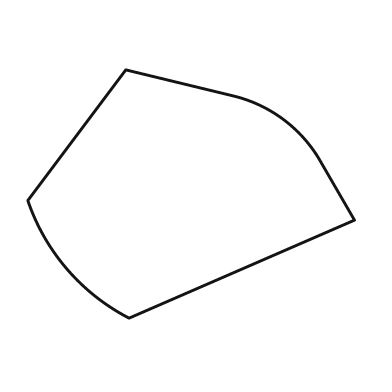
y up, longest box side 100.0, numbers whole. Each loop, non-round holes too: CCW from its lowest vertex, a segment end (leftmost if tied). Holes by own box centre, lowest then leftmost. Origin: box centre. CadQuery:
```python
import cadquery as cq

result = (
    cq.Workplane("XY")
    .moveTo(-19.0, -38.0)
    .lineTo(50.0, -8.0)
    .lineTo(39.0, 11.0)
    .threePointArc((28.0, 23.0), (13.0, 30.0))
    .lineTo(-20.0, 38.0)
    .lineTo(-50.0, -2.0)
    .threePointArc((-38.0, -23.0), (-19.0, -38.0))
    .close()
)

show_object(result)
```